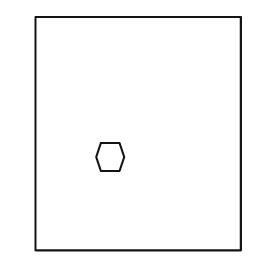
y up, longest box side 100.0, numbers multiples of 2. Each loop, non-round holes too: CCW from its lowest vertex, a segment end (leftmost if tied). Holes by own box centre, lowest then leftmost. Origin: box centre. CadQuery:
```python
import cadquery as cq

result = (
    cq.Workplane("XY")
    .moveTo(-44.0, -50.0)
    .lineTo(44.0, -50.0)
    .lineTo(44.0, 50.0)
    .lineTo(-44.0, 50.0)
    .close()
    .moveTo(-16.0, -16.0)
    .lineTo(-8.0, -16.0)
    .lineTo(-6.0, -10.0)
    .lineTo(-8.0, -4.0)
    .lineTo(-16.0, -4.0)
    .lineTo(-18.0, -10.0)
    .close()
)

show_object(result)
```